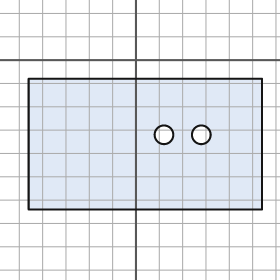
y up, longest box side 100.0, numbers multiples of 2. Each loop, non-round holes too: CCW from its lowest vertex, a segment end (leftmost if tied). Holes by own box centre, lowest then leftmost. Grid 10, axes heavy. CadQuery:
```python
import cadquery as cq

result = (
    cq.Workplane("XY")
    .moveTo(-46.0, -64.0)
    .lineTo(54.0, -64.0)
    .lineTo(54.0, -8.0)
    .lineTo(-46.0, -8.0)
    .close()
    .moveTo(12.0, -32.0)
    .circle(4.0)
    .moveTo(28.0, -32.0)
    .circle(4.0)
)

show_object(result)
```